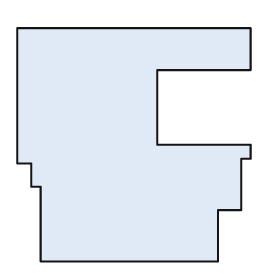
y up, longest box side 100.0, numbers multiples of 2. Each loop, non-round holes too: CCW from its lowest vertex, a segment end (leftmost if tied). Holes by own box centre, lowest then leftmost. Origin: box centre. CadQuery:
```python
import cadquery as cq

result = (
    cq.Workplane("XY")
    .moveTo(-40.0, -50.0)
    .lineTo(36.0, -50.0)
    .lineTo(36.0, -28.0)
    .lineTo(46.0, -28.0)
    .lineTo(46.0, -6.0)
    .lineTo(50.0, -6.0)
    .lineTo(50.0, 0.0)
    .lineTo(10.0, 0.0)
    .lineTo(10.0, 32.0)
    .lineTo(50.0, 32.0)
    .lineTo(50.0, 50.0)
    .lineTo(-50.0, 50.0)
    .lineTo(-50.0, -8.0)
    .lineTo(-44.0, -8.0)
    .lineTo(-44.0, -18.0)
    .lineTo(-40.0, -18.0)
    .close()
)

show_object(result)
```